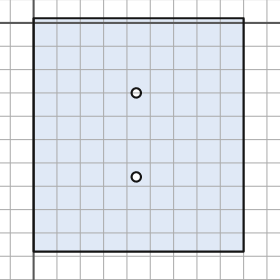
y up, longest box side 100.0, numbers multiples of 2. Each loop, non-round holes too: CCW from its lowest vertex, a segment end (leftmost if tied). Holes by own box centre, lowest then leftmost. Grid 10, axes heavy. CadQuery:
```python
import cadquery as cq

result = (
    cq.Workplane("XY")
    .moveTo(0.0, -98.0)
    .lineTo(90.0, -98.0)
    .lineTo(90.0, 2.0)
    .lineTo(0.0, 2.0)
    .close()
    .moveTo(44.0, -66.0)
    .circle(2.0)
    .moveTo(44.0, -30.0)
    .circle(2.0)
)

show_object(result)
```